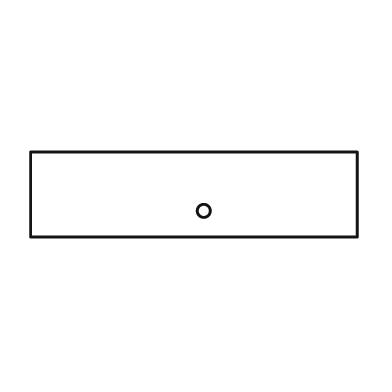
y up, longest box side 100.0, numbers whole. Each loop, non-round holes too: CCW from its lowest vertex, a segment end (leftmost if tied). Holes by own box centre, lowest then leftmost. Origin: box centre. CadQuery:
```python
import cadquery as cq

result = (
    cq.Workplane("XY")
    .moveTo(-50.0, -13.0)
    .lineTo(50.0, -13.0)
    .lineTo(50.0, 13.0)
    .lineTo(-50.0, 13.0)
    .close()
    .moveTo(3.0, -5.0)
    .circle(2.0)
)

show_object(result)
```